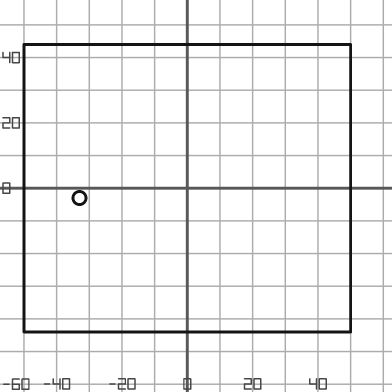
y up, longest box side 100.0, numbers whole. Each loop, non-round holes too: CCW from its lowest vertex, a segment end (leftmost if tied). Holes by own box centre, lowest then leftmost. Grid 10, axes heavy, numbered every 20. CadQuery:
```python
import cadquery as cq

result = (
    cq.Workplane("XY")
    .moveTo(-50.0, -44.0)
    .lineTo(50.0, -44.0)
    .lineTo(50.0, 44.0)
    .lineTo(-50.0, 44.0)
    .close()
    .moveTo(-33.0, -3.0)
    .circle(2.0)
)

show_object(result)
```